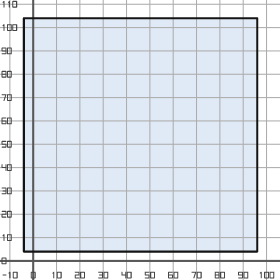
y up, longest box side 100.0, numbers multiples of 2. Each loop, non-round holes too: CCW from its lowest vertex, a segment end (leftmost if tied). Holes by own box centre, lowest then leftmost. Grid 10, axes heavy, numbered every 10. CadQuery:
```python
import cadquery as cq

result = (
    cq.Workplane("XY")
    .moveTo(-4.0, 4.0)
    .lineTo(96.0, 4.0)
    .lineTo(96.0, 104.0)
    .lineTo(-4.0, 104.0)
    .close()
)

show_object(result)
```